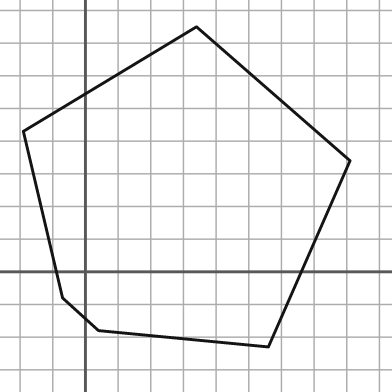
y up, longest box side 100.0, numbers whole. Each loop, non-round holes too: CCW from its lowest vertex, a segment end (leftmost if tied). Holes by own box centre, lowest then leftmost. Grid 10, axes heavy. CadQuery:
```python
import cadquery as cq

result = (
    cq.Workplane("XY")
    .moveTo(56.0, -23.0)
    .lineTo(81.0, 34.0)
    .lineTo(34.0, 75.0)
    .lineTo(-19.0, 43.0)
    .lineTo(-7.0, -8.0)
    .lineTo(4.0, -18.0)
    .close()
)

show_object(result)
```